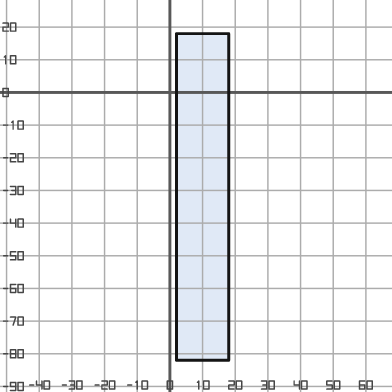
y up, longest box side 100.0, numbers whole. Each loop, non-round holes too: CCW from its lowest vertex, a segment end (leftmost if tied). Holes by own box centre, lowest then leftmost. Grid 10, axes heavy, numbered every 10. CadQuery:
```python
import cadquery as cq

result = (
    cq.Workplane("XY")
    .moveTo(2.0, -82.0)
    .lineTo(18.0, -82.0)
    .lineTo(18.0, 18.0)
    .lineTo(2.0, 18.0)
    .close()
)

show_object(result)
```